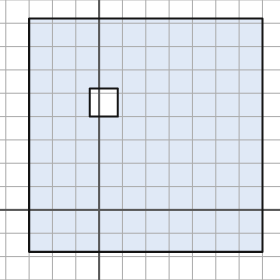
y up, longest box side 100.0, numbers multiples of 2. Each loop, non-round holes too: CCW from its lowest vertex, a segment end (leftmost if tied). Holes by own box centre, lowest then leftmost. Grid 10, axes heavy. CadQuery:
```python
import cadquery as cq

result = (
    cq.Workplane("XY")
    .moveTo(-30.0, -18.0)
    .lineTo(70.0, -18.0)
    .lineTo(70.0, 82.0)
    .lineTo(-30.0, 82.0)
    .close()
    .moveTo(-4.0, 40.0)
    .lineTo(8.0, 40.0)
    .lineTo(8.0, 52.0)
    .lineTo(-4.0, 52.0)
    .close()
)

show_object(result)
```